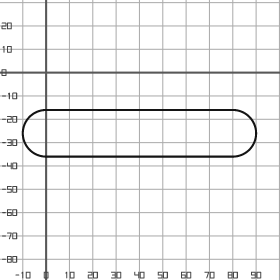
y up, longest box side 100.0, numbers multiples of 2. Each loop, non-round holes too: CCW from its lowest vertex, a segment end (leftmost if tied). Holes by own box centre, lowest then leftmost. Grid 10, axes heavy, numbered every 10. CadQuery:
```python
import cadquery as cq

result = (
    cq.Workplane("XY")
    .moveTo(0.0, -36.0)
    .lineTo(80.0, -36.0)
    .threePointArc((90.0, -26.0), (80.0, -16.0))
    .lineTo(0.0, -16.0)
    .threePointArc((-10.0, -26.0), (0.0, -36.0))
    .close()
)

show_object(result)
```